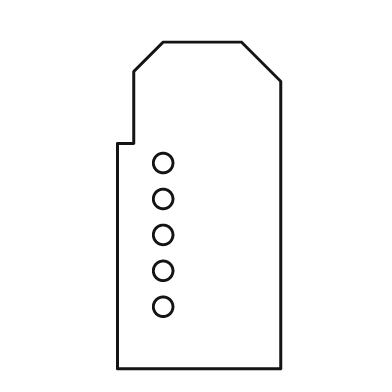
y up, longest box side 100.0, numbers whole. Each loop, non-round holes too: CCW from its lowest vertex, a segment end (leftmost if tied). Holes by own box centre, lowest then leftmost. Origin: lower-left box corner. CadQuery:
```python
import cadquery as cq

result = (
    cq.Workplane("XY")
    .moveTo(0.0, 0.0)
    .lineTo(50.0, 0.0)
    .lineTo(50.0, 88.0)
    .lineTo(38.0, 100.0)
    .lineTo(14.0, 100.0)
    .lineTo(5.0, 91.0)
    .lineTo(5.0, 69.0)
    .lineTo(0.0, 69.0)
    .close()
    .moveTo(14.0, 19.0)
    .circle(3.0)
    .moveTo(14.0, 30.0)
    .circle(3.0)
    .moveTo(14.0, 41.0)
    .circle(3.0)
    .moveTo(14.0, 52.0)
    .circle(3.0)
    .moveTo(14.0, 63.0)
    .circle(3.0)
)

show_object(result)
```